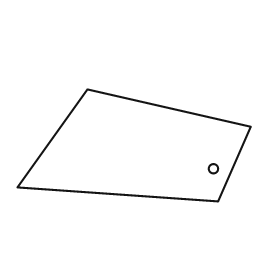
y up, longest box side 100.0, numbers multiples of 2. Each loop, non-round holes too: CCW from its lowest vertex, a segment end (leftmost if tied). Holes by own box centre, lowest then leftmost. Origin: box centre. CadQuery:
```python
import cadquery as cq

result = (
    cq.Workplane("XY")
    .moveTo(36.0, -24.0)
    .lineTo(50.0, 8.0)
    .lineTo(-20.0, 24.0)
    .lineTo(-50.0, -18.0)
    .close()
    .moveTo(34.0, -10.0)
    .circle(2.0)
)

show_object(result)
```